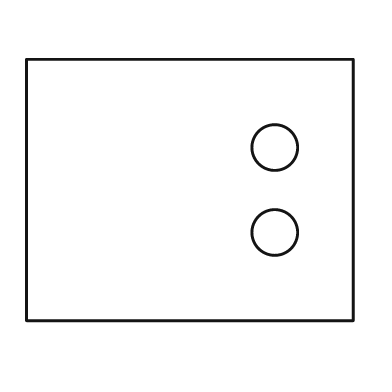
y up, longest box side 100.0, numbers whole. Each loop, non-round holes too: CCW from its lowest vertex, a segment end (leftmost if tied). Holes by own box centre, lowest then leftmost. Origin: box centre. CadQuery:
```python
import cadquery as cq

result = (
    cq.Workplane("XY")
    .moveTo(-50.0, -40.0)
    .lineTo(50.0, -40.0)
    .lineTo(50.0, 40.0)
    .lineTo(-50.0, 40.0)
    .close()
    .moveTo(26.0, -13.0)
    .circle(7.0)
    .moveTo(26.0, 13.0)
    .circle(7.0)
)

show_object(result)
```